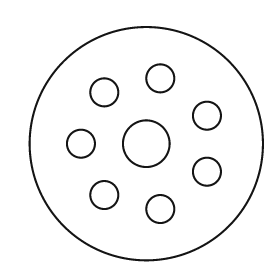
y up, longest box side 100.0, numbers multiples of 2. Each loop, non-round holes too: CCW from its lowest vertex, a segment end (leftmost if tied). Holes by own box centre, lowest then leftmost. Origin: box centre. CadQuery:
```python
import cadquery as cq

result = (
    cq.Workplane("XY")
    .moveTo(0.0, 0.0)
    .circle(50.0)
    .moveTo(6.0, -28.0)
    .circle(6.0)
    .moveTo(-18.0, -22.0)
    .circle(6.0)
    .moveTo(26.0, -12.0)
    .circle(6.0)
    .moveTo(-28.0, 0.0)
    .circle(6.0)
    .moveTo(0.0, 0.0)
    .circle(10.0)
    .moveTo(26.0, 12.0)
    .circle(6.0)
    .moveTo(-18.0, 22.0)
    .circle(6.0)
    .moveTo(6.0, 28.0)
    .circle(6.0)
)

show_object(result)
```